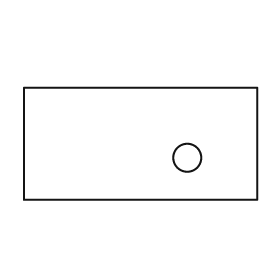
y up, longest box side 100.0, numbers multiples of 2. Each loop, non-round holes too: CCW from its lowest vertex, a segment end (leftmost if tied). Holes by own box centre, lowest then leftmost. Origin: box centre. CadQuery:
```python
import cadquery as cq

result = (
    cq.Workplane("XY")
    .moveTo(-50.0, -24.0)
    .lineTo(50.0, -24.0)
    .lineTo(50.0, 24.0)
    .lineTo(-50.0, 24.0)
    .close()
    .moveTo(20.0, -6.0)
    .circle(6.0)
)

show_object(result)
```